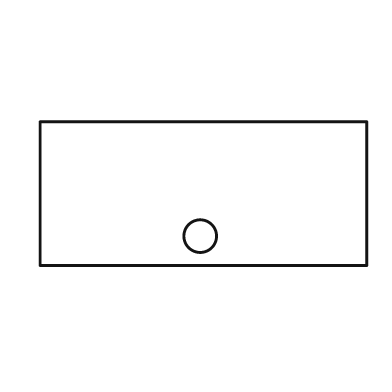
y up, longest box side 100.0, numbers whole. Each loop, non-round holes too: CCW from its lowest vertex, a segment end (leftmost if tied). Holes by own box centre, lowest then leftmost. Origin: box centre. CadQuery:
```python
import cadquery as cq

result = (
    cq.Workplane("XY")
    .moveTo(-50.0, -22.0)
    .lineTo(50.0, -22.0)
    .lineTo(50.0, 22.0)
    .lineTo(-50.0, 22.0)
    .close()
    .moveTo(-1.0, -13.0)
    .circle(5.0)
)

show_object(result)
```